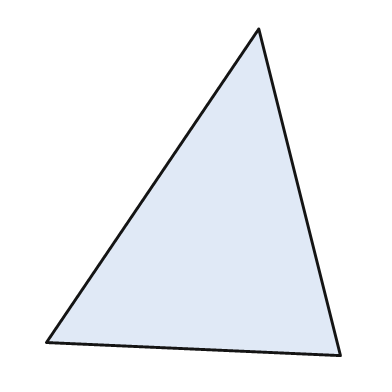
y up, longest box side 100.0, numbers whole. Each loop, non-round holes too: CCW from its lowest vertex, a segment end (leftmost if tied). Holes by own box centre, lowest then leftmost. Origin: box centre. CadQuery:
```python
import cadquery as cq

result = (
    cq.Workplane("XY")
    .moveTo(45.0, -50.0)
    .lineTo(20.0, 50.0)
    .lineTo(-45.0, -46.0)
    .close()
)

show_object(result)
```